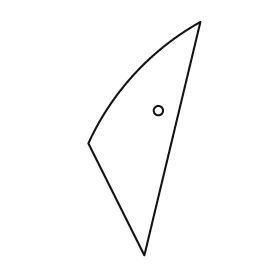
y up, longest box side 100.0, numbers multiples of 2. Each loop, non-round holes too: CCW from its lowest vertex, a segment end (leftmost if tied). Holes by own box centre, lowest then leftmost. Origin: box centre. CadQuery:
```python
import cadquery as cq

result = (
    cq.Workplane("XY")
    .moveTo(0.0, -50.0)
    .lineTo(24.0, 50.0)
    .threePointArc((-4.0, 28.0), (-24.0, -2.0))
    .close()
    .moveTo(6.0, 12.0)
    .circle(2.0)
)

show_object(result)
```